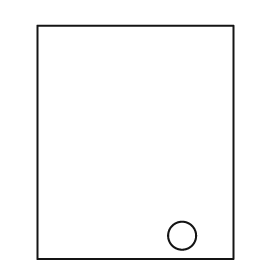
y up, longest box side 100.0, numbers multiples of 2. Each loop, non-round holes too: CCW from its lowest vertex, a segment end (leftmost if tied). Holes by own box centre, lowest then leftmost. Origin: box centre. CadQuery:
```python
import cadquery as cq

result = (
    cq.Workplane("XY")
    .moveTo(-42.0, -50.0)
    .lineTo(42.0, -50.0)
    .lineTo(42.0, 50.0)
    .lineTo(-42.0, 50.0)
    .close()
    .moveTo(20.0, -40.0)
    .circle(6.0)
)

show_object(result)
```